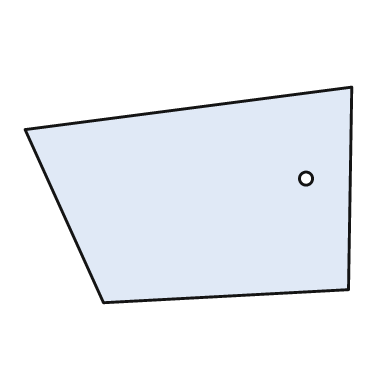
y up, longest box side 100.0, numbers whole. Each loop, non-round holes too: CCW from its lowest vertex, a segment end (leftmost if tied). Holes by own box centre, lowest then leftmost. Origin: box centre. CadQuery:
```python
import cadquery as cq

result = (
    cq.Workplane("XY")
    .moveTo(-26.0, -33.0)
    .lineTo(49.0, -29.0)
    .lineTo(50.0, 33.0)
    .lineTo(-50.0, 20.0)
    .close()
    .moveTo(36.0, 5.0)
    .circle(2.0)
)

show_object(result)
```